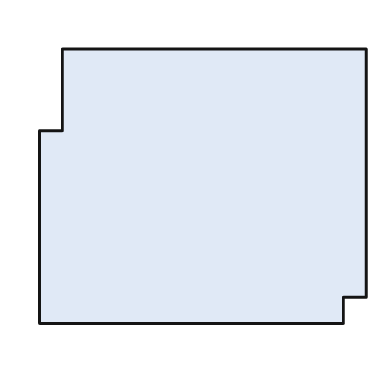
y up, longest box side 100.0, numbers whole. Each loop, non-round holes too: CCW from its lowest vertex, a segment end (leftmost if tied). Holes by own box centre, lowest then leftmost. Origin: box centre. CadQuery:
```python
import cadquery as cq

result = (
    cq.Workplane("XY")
    .moveTo(-50.0, -42.0)
    .lineTo(43.0, -42.0)
    .lineTo(43.0, -34.0)
    .lineTo(50.0, -34.0)
    .lineTo(50.0, 42.0)
    .lineTo(-43.0, 42.0)
    .lineTo(-43.0, 17.0)
    .lineTo(-50.0, 17.0)
    .close()
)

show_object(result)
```